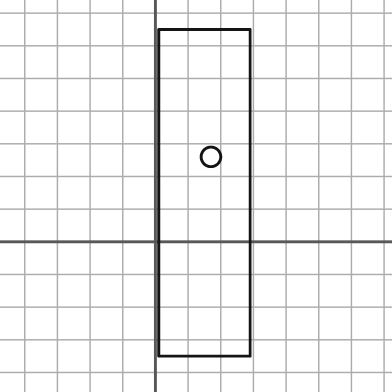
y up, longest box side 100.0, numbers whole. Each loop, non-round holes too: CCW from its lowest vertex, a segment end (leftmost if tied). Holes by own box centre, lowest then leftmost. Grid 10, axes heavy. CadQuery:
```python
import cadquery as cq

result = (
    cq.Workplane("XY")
    .moveTo(1.0, -35.0)
    .lineTo(29.0, -35.0)
    .lineTo(29.0, 65.0)
    .lineTo(1.0, 65.0)
    .close()
    .moveTo(17.0, 26.0)
    .circle(3.0)
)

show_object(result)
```